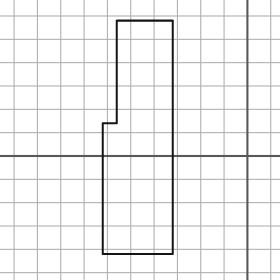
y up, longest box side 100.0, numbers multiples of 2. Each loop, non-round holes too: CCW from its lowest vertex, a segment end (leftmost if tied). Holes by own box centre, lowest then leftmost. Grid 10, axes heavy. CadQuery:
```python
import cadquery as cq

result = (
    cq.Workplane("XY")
    .moveTo(-62.0, -42.0)
    .lineTo(-32.0, -42.0)
    .lineTo(-32.0, 58.0)
    .lineTo(-56.0, 58.0)
    .lineTo(-56.0, 14.0)
    .lineTo(-62.0, 14.0)
    .close()
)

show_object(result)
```